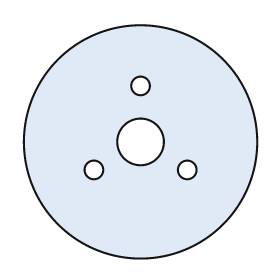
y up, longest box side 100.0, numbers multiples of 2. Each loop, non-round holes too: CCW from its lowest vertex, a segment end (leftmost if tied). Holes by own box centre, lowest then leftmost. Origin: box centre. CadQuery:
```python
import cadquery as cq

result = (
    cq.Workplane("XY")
    .moveTo(0.0, 0.0)
    .circle(50.0)
    .moveTo(-20.0, -12.0)
    .circle(4.0)
    .moveTo(20.0, -12.0)
    .circle(4.0)
    .moveTo(0.0, 0.0)
    .circle(10.0)
    .moveTo(0.0, 24.0)
    .circle(4.0)
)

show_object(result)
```